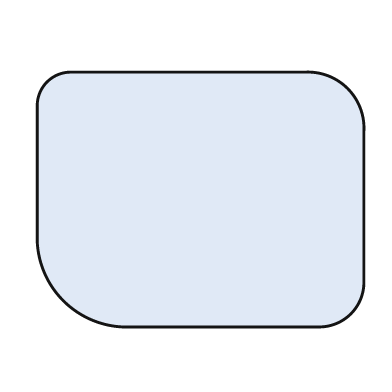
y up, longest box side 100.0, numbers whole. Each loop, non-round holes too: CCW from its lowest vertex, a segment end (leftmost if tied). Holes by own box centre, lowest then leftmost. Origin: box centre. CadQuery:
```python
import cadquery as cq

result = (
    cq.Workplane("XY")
    .moveTo(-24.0, -39.0)
    .lineTo(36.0, -39.0)
    .threePointArc((46.0, -35.0), (50.0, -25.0))
    .lineTo(50.0, 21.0)
    .threePointArc((45.0, 34.0), (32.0, 39.0))
    .lineTo(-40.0, 39.0)
    .threePointArc((-47.0, 36.0), (-50.0, 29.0))
    .lineTo(-50.0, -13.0)
    .threePointArc((-42.0, -31.0), (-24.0, -39.0))
    .close()
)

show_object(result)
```